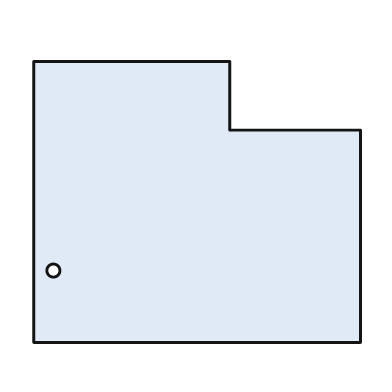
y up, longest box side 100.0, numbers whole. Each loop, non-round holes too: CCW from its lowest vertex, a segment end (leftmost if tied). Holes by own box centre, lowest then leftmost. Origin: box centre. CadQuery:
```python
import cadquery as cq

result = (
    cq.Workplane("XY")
    .moveTo(-50.0, -43.0)
    .lineTo(50.0, -43.0)
    .lineTo(50.0, 22.0)
    .lineTo(10.0, 22.0)
    .lineTo(10.0, 43.0)
    .lineTo(-50.0, 43.0)
    .close()
    .moveTo(-44.0, -21.0)
    .circle(2.0)
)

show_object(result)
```